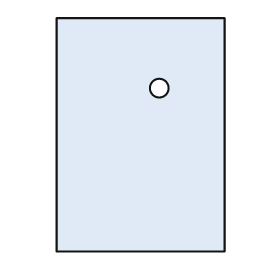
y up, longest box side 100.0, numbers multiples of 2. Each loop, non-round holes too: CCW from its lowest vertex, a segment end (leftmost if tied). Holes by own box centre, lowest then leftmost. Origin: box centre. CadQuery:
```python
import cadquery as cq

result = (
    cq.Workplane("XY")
    .moveTo(-36.0, -50.0)
    .lineTo(36.0, -50.0)
    .lineTo(36.0, 50.0)
    .lineTo(-36.0, 50.0)
    .close()
    .moveTo(8.0, 20.0)
    .circle(4.0)
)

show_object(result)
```